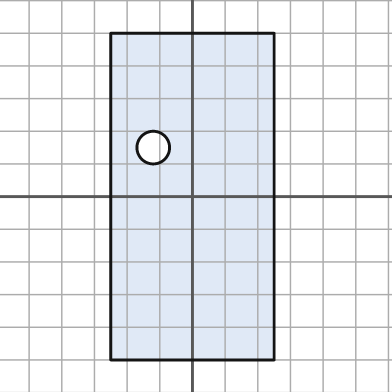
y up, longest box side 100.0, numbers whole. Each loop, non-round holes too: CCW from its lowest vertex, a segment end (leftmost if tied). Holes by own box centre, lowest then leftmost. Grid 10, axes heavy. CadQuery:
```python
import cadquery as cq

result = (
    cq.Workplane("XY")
    .moveTo(-25.0, -50.0)
    .lineTo(25.0, -50.0)
    .lineTo(25.0, 50.0)
    .lineTo(-25.0, 50.0)
    .close()
    .moveTo(-12.0, 15.0)
    .circle(5.0)
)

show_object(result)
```